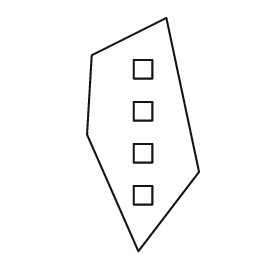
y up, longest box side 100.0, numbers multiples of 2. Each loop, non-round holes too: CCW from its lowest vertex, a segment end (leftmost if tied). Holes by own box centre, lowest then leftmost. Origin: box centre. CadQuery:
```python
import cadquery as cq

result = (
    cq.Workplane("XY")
    .moveTo(-2.0, -50.0)
    .lineTo(24.0, -16.0)
    .lineTo(10.0, 50.0)
    .lineTo(-22.0, 34.0)
    .lineTo(-24.0, 0.0)
    .close()
    .moveTo(-4.0, -30.0)
    .lineTo(4.0, -30.0)
    .lineTo(4.0, -22.0)
    .lineTo(-4.0, -22.0)
    .close()
    .moveTo(-4.0, -12.0)
    .lineTo(4.0, -12.0)
    .lineTo(4.0, -4.0)
    .lineTo(-4.0, -4.0)
    .close()
    .moveTo(-4.0, 6.0)
    .lineTo(4.0, 6.0)
    .lineTo(4.0, 14.0)
    .lineTo(-4.0, 14.0)
    .close()
    .moveTo(-4.0, 24.0)
    .lineTo(4.0, 24.0)
    .lineTo(4.0, 32.0)
    .lineTo(-4.0, 32.0)
    .close()
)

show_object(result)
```